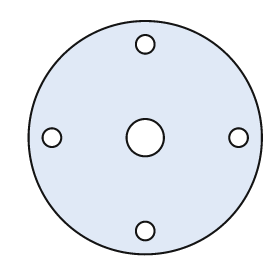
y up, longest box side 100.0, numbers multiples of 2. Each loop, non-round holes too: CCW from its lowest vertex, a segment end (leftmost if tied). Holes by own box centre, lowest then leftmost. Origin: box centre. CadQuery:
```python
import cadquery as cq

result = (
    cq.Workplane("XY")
    .moveTo(0.0, 0.0)
    .circle(50.0)
    .moveTo(0.0, -40.0)
    .circle(4.0)
    .moveTo(-40.0, 0.0)
    .circle(4.0)
    .moveTo(0.0, 0.0)
    .circle(8.0)
    .moveTo(40.0, 0.0)
    .circle(4.0)
    .moveTo(0.0, 40.0)
    .circle(4.0)
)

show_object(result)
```